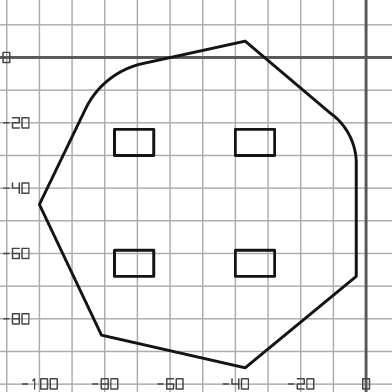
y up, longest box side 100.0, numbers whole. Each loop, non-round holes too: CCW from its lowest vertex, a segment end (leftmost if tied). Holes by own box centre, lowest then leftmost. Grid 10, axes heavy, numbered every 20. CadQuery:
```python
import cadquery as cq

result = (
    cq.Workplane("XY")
    .moveTo(-37.0, -95.0)
    .lineTo(-3.0, -67.0)
    .lineTo(-3.0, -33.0)
    .threePointArc((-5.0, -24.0), (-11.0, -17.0))
    .lineTo(-37.0, 5.0)
    .lineTo(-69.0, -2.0)
    .threePointArc((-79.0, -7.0), (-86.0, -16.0))
    .lineTo(-100.0, -45.0)
    .lineTo(-81.0, -85.0)
    .close()
    .moveTo(-77.0, -67.0)
    .lineTo(-65.0, -67.0)
    .lineTo(-65.0, -59.0)
    .lineTo(-77.0, -59.0)
    .close()
    .moveTo(-40.0, -67.0)
    .lineTo(-28.0, -67.0)
    .lineTo(-28.0, -59.0)
    .lineTo(-40.0, -59.0)
    .close()
    .moveTo(-77.0, -30.0)
    .lineTo(-65.0, -30.0)
    .lineTo(-65.0, -22.0)
    .lineTo(-77.0, -22.0)
    .close()
    .moveTo(-40.0, -30.0)
    .lineTo(-28.0, -30.0)
    .lineTo(-28.0, -22.0)
    .lineTo(-40.0, -22.0)
    .close()
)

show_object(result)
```